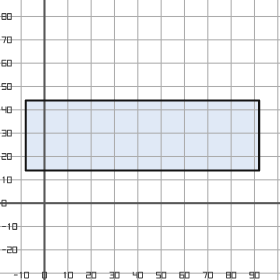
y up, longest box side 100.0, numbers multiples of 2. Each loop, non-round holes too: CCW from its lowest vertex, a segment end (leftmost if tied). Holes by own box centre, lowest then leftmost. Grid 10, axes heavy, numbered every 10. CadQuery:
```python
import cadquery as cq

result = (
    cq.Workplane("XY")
    .moveTo(-8.0, 14.0)
    .lineTo(92.0, 14.0)
    .lineTo(92.0, 44.0)
    .lineTo(-8.0, 44.0)
    .close()
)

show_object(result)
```